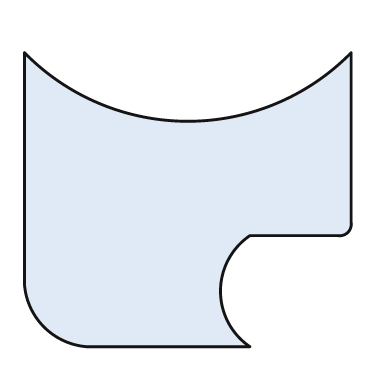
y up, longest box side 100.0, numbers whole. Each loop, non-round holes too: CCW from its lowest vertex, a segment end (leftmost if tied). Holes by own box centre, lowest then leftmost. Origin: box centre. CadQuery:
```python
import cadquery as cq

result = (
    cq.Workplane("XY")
    .moveTo(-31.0, -45.0)
    .lineTo(19.0, -45.0)
    .threePointArc((10.0, -28.0), (19.0, -11.0))
    .lineTo(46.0, -11.0)
    .threePointArc((49.0, -10.0), (50.0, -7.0))
    .lineTo(50.0, 45.0)
    .threePointArc((0.0, 24.0), (-50.0, 45.0))
    .lineTo(-50.0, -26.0)
    .threePointArc((-44.0, -39.0), (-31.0, -45.0))
    .close()
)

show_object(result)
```